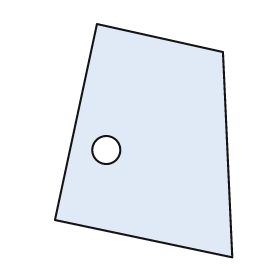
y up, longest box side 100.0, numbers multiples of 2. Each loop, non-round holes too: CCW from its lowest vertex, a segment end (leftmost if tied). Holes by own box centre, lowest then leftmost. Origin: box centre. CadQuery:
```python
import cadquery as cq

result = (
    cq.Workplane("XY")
    .moveTo(38.0, -50.0)
    .lineTo(34.0, 38.0)
    .lineTo(-20.0, 50.0)
    .lineTo(-38.0, -34.0)
    .close()
    .moveTo(-16.0, -4.0)
    .circle(6.0)
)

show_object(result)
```